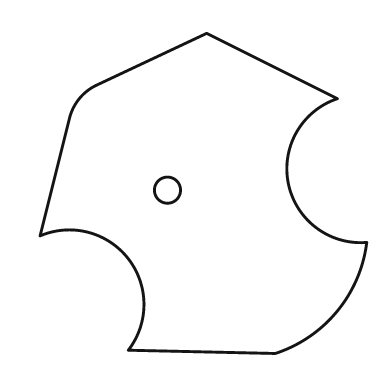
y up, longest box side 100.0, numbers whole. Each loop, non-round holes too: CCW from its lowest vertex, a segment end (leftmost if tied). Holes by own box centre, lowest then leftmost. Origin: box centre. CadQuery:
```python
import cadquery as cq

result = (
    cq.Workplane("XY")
    .moveTo(22.0, -49.0)
    .threePointArc((41.0, -36.0), (50.0, -15.0))
    .threePointArc((26.0, 3.0), (41.0, 29.0))
    .lineTo(1.0, 49.0)
    .lineTo(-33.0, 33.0)
    .threePointArc((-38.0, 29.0), (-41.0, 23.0))
    .lineTo(-50.0, -13.0)
    .threePointArc((-23.0, -20.0), (-23.0, -48.0))
    .close()
    .moveTo(-11.0, 1.0)
    .circle(4.0)
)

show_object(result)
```